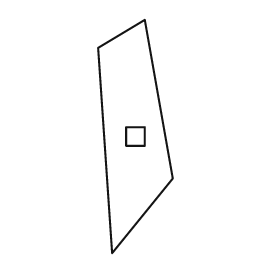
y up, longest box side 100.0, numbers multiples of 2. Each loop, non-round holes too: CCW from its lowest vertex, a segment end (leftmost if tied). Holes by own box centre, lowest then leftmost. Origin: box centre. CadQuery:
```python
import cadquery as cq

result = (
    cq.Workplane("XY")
    .moveTo(-10.0, -50.0)
    .lineTo(16.0, -18.0)
    .lineTo(4.0, 50.0)
    .lineTo(-16.0, 38.0)
    .close()
    .moveTo(-4.0, -4.0)
    .lineTo(4.0, -4.0)
    .lineTo(4.0, 4.0)
    .lineTo(-4.0, 4.0)
    .close()
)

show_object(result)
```